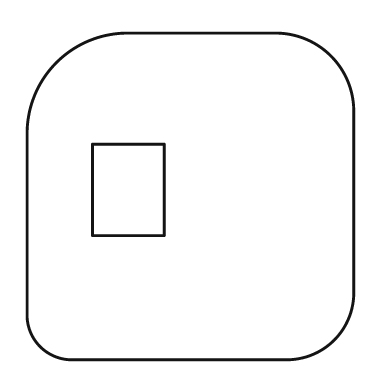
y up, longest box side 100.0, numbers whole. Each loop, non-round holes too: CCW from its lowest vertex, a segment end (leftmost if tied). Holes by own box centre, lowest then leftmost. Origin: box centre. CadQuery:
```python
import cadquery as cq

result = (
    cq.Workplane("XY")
    .moveTo(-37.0, -50.0)
    .lineTo(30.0, -50.0)
    .threePointArc((44.0, -44.0), (50.0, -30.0))
    .lineTo(50.0, 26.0)
    .threePointArc((43.0, 43.0), (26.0, 50.0))
    .lineTo(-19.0, 50.0)
    .threePointArc((-41.0, 41.0), (-50.0, 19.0))
    .lineTo(-50.0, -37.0)
    .threePointArc((-46.0, -46.0), (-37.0, -50.0))
    .close()
    .moveTo(-30.0, -12.0)
    .lineTo(-8.0, -12.0)
    .lineTo(-8.0, 16.0)
    .lineTo(-30.0, 16.0)
    .close()
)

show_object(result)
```